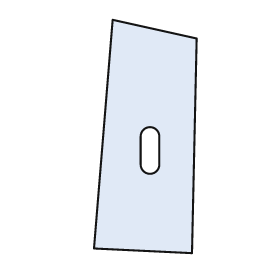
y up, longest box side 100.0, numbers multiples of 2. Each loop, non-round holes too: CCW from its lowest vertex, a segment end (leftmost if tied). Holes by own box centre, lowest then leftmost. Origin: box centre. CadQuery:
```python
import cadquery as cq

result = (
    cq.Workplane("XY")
    .moveTo(20.0, -50.0)
    .lineTo(22.0, 42.0)
    .lineTo(-14.0, 50.0)
    .lineTo(-22.0, -48.0)
    .close()
    .moveTo(-2.0, -12.0)
    .threePointArc((2.0, -16.0), (6.0, -12.0))
    .lineTo(6.0, 0.0)
    .threePointArc((2.0, 4.0), (-2.0, 0.0))
    .close()
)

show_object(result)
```